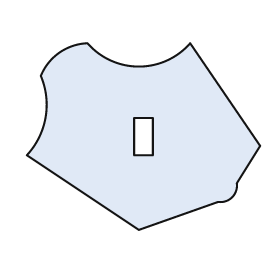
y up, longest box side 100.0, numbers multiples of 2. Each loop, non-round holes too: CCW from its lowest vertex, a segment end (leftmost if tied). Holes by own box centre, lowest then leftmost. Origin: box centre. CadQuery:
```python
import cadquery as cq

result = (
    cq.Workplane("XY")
    .moveTo(-2.0, -40.0)
    .lineTo(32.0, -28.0)
    .threePointArc((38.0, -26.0), (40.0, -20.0))
    .lineTo(50.0, -4.0)
    .lineTo(20.0, 40.0)
    .threePointArc((-2.0, 30.0), (-24.0, 40.0))
    .threePointArc((-36.0, 36.0), (-44.0, 26.0))
    .threePointArc((-42.0, 8.0), (-50.0, -8.0))
    .close()
    .moveTo(-4.0, -8.0)
    .lineTo(4.0, -8.0)
    .lineTo(4.0, 8.0)
    .lineTo(-4.0, 8.0)
    .close()
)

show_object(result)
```